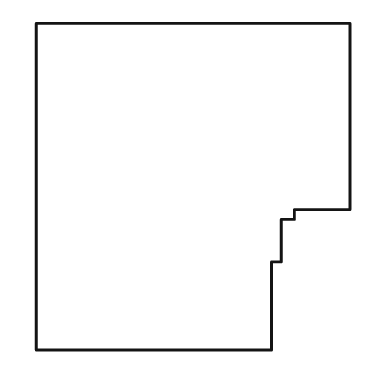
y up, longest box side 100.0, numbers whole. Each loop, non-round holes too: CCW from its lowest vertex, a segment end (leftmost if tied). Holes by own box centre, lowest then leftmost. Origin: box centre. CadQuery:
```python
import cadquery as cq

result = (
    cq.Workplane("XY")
    .moveTo(-48.0, -50.0)
    .lineTo(24.0, -50.0)
    .lineTo(24.0, -23.0)
    .lineTo(27.0, -23.0)
    .lineTo(27.0, -10.0)
    .lineTo(31.0, -10.0)
    .lineTo(31.0, -7.0)
    .lineTo(48.0, -7.0)
    .lineTo(48.0, 50.0)
    .lineTo(-48.0, 50.0)
    .close()
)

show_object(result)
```